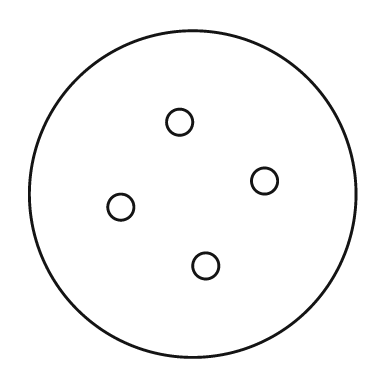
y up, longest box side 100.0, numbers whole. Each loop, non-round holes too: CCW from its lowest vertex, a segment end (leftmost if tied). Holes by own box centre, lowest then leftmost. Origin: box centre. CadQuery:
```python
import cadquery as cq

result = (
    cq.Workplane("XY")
    .moveTo(0.0, 0.0)
    .circle(50.0)
    .moveTo(4.0, -22.0)
    .circle(4.0)
    .moveTo(-22.0, -4.0)
    .circle(4.0)
    .moveTo(22.0, 4.0)
    .circle(4.0)
    .moveTo(-4.0, 22.0)
    .circle(4.0)
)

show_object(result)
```